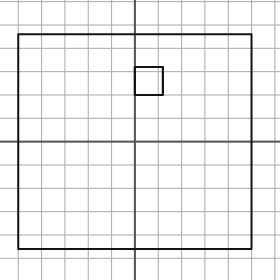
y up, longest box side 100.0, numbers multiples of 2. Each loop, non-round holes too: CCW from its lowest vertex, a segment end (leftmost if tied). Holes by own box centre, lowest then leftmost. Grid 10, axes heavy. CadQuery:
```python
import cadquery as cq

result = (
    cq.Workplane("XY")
    .moveTo(-50.0, -46.0)
    .lineTo(50.0, -46.0)
    .lineTo(50.0, 46.0)
    .lineTo(-50.0, 46.0)
    .close()
    .moveTo(0.0, 20.0)
    .lineTo(12.0, 20.0)
    .lineTo(12.0, 32.0)
    .lineTo(0.0, 32.0)
    .close()
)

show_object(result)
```